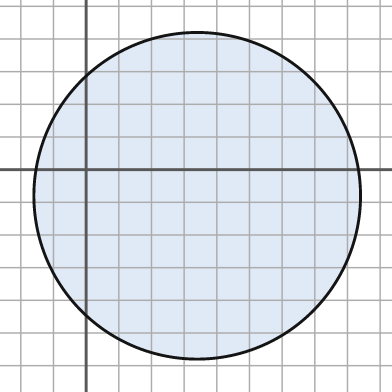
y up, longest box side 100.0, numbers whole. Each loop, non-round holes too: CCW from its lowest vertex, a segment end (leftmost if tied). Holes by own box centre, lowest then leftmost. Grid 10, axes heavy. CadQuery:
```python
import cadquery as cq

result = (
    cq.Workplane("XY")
    .moveTo(34.0, -8.0)
    .circle(50.0)
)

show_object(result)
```